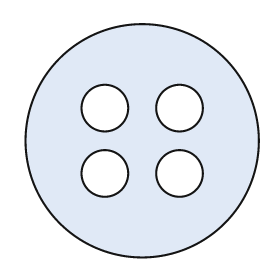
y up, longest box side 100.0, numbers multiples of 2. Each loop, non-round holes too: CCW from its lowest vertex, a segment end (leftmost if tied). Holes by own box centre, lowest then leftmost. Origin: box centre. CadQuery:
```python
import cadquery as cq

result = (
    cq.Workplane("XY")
    .moveTo(0.0, 0.0)
    .circle(50.0)
    .moveTo(-16.0, -14.0)
    .circle(10.0)
    .moveTo(16.0, -14.0)
    .circle(10.0)
    .moveTo(-16.0, 14.0)
    .circle(10.0)
    .moveTo(16.0, 14.0)
    .circle(10.0)
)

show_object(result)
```